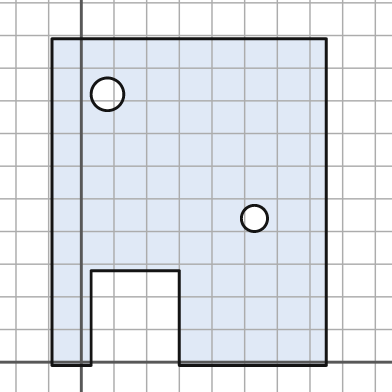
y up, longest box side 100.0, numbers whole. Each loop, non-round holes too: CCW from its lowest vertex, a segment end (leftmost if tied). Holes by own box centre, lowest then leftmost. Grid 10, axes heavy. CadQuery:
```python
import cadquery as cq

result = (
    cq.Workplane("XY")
    .moveTo(-9.0, -1.0)
    .lineTo(3.0, -1.0)
    .lineTo(3.0, 28.0)
    .lineTo(30.0, 28.0)
    .lineTo(30.0, -1.0)
    .lineTo(75.0, -1.0)
    .lineTo(75.0, 99.0)
    .lineTo(-9.0, 99.0)
    .close()
    .moveTo(53.0, 44.0)
    .circle(4.0)
    .moveTo(8.0, 82.0)
    .circle(5.0)
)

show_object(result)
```